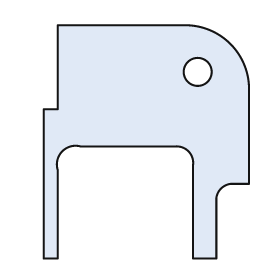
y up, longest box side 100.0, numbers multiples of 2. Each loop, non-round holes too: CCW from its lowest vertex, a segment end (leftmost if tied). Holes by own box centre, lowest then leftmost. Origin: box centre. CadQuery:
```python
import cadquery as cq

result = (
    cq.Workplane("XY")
    .moveTo(-44.0, -50.0)
    .lineTo(-38.0, -50.0)
    .lineTo(-38.0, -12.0)
    .threePointArc((-36.0, -4.0), (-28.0, -2.0))
    .lineTo(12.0, -2.0)
    .threePointArc((18.0, -4.0), (20.0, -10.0))
    .lineTo(20.0, -50.0)
    .lineTo(30.0, -50.0)
    .lineTo(30.0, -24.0)
    .threePointArc((32.0, -20.0), (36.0, -18.0))
    .lineTo(44.0, -18.0)
    .lineTo(44.0, 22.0)
    .threePointArc((36.0, 42.0), (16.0, 50.0))
    .lineTo(-38.0, 50.0)
    .lineTo(-38.0, 14.0)
    .lineTo(-44.0, 14.0)
    .close()
    .moveTo(22.0, 30.0)
    .circle(6.0)
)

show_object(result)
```